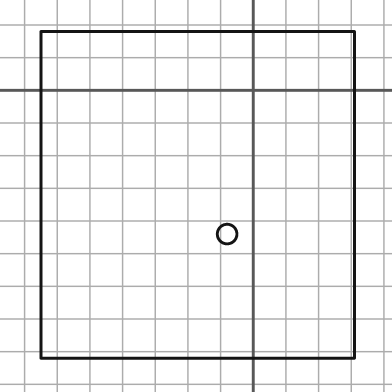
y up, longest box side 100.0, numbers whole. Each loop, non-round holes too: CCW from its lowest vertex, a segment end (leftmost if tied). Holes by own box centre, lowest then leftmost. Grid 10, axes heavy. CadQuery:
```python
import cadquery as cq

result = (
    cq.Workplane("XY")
    .moveTo(-65.0, -82.0)
    .lineTo(31.0, -82.0)
    .lineTo(31.0, 18.0)
    .lineTo(-65.0, 18.0)
    .close()
    .moveTo(-8.0, -44.0)
    .circle(3.0)
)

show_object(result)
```